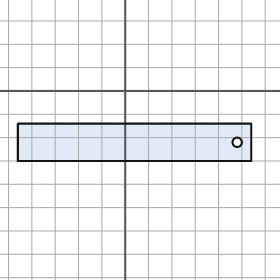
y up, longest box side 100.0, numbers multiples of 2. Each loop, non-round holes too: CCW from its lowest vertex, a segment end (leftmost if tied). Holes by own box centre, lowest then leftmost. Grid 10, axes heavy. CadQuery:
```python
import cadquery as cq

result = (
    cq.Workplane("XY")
    .moveTo(-46.0, -30.0)
    .lineTo(54.0, -30.0)
    .lineTo(54.0, -14.0)
    .lineTo(-46.0, -14.0)
    .close()
    .moveTo(48.0, -22.0)
    .circle(2.0)
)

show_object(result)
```